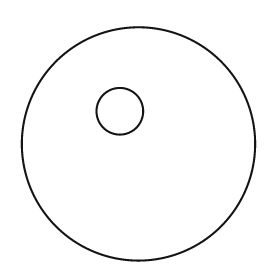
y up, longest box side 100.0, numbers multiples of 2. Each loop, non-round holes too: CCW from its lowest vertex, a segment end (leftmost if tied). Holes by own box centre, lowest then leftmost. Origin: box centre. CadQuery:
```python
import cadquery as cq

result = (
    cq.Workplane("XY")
    .moveTo(0.0, 0.0)
    .circle(50.0)
    .moveTo(-8.0, 14.0)
    .circle(10.0)
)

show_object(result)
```